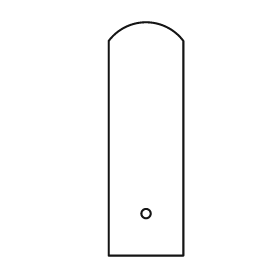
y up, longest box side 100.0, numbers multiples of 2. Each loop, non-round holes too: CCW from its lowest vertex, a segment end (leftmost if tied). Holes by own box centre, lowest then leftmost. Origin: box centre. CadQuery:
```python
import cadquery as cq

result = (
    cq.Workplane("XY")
    .moveTo(-16.0, -50.0)
    .lineTo(16.0, -50.0)
    .lineTo(16.0, 42.0)
    .threePointArc((0.0, 50.0), (-16.0, 42.0))
    .close()
    .moveTo(0.0, -32.0)
    .circle(2.0)
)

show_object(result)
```